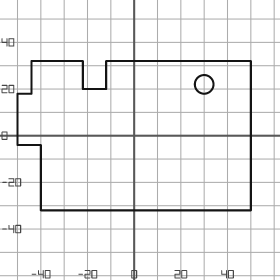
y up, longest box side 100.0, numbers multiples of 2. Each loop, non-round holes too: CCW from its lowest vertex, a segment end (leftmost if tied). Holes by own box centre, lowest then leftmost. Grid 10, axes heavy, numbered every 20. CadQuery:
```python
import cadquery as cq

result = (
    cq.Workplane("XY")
    .moveTo(-40.0, -32.0)
    .lineTo(50.0, -32.0)
    .lineTo(50.0, 32.0)
    .lineTo(-12.0, 32.0)
    .lineTo(-12.0, 20.0)
    .lineTo(-22.0, 20.0)
    .lineTo(-22.0, 32.0)
    .lineTo(-44.0, 32.0)
    .lineTo(-44.0, 18.0)
    .lineTo(-50.0, 18.0)
    .lineTo(-50.0, -4.0)
    .lineTo(-40.0, -4.0)
    .close()
    .moveTo(30.0, 22.0)
    .circle(4.0)
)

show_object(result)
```